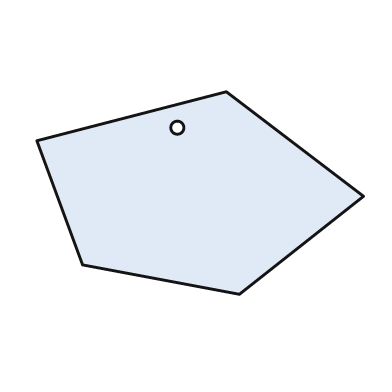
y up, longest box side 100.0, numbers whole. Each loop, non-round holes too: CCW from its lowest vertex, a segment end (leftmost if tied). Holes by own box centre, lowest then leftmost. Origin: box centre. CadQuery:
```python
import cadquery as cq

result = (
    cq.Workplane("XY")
    .moveTo(12.0, -31.0)
    .lineTo(50.0, -1.0)
    .lineTo(8.0, 31.0)
    .lineTo(-50.0, 16.0)
    .lineTo(-36.0, -22.0)
    .close()
    .moveTo(-7.0, 20.0)
    .circle(2.0)
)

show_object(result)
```